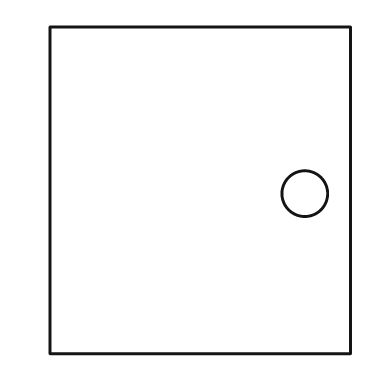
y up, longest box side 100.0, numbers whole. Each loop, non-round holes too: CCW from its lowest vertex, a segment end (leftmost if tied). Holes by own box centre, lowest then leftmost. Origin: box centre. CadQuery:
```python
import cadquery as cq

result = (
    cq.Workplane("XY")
    .moveTo(-46.0, -50.0)
    .lineTo(46.0, -50.0)
    .lineTo(46.0, 50.0)
    .lineTo(-46.0, 50.0)
    .close()
    .moveTo(32.0, -1.0)
    .circle(7.0)
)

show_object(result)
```